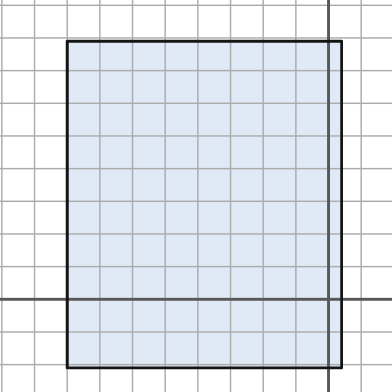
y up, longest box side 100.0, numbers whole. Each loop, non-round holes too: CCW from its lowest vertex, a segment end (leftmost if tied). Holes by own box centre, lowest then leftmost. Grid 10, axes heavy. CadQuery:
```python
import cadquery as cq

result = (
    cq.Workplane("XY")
    .moveTo(-80.0, -21.0)
    .lineTo(4.0, -21.0)
    .lineTo(4.0, 79.0)
    .lineTo(-80.0, 79.0)
    .close()
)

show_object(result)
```